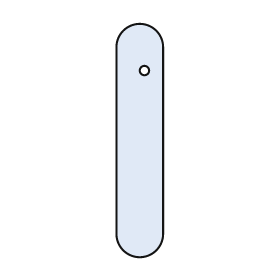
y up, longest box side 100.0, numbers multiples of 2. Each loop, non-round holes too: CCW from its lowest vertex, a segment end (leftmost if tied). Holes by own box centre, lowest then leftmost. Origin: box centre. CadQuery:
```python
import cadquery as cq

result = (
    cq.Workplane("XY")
    .moveTo(-10.0, -40.0)
    .threePointArc((0.0, -50.0), (10.0, -40.0))
    .lineTo(10.0, 40.0)
    .threePointArc((0.0, 50.0), (-10.0, 40.0))
    .close()
    .moveTo(2.0, 30.0)
    .circle(2.0)
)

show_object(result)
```